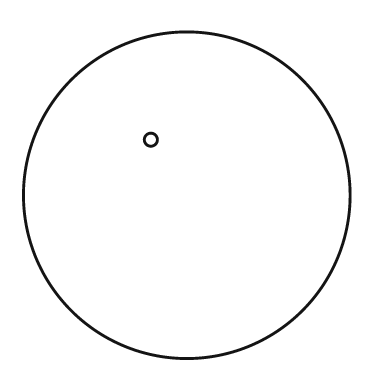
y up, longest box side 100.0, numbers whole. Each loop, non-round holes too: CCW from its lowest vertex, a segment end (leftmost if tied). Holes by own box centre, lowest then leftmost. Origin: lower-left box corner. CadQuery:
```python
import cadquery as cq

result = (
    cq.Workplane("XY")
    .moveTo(50.0, 50.0)
    .circle(50.0)
    .moveTo(39.0, 67.0)
    .circle(2.0)
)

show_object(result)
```